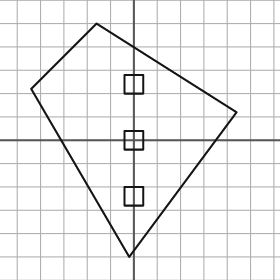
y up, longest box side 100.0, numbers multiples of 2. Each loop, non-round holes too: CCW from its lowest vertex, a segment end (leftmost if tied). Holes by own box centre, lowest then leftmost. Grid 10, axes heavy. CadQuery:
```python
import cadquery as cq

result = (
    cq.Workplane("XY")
    .moveTo(-2.0, -50.0)
    .lineTo(44.0, 12.0)
    .lineTo(-16.0, 50.0)
    .lineTo(-44.0, 22.0)
    .close()
    .moveTo(-4.0, -28.0)
    .lineTo(4.0, -28.0)
    .lineTo(4.0, -20.0)
    .lineTo(-4.0, -20.0)
    .close()
    .moveTo(-4.0, -4.0)
    .lineTo(4.0, -4.0)
    .lineTo(4.0, 4.0)
    .lineTo(-4.0, 4.0)
    .close()
    .moveTo(-4.0, 20.0)
    .lineTo(4.0, 20.0)
    .lineTo(4.0, 28.0)
    .lineTo(-4.0, 28.0)
    .close()
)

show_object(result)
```